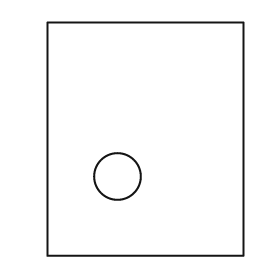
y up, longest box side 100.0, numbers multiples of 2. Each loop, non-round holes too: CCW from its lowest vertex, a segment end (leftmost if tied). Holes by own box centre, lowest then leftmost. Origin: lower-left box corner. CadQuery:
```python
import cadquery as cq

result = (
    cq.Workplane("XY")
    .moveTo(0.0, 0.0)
    .lineTo(84.0, 0.0)
    .lineTo(84.0, 100.0)
    .lineTo(0.0, 100.0)
    .close()
    .moveTo(30.0, 34.0)
    .circle(10.0)
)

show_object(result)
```